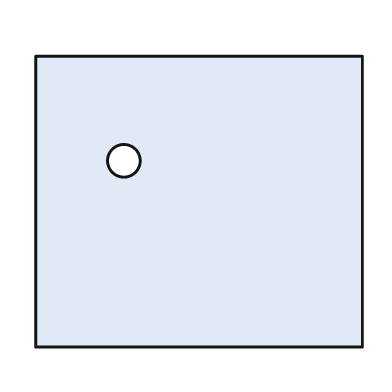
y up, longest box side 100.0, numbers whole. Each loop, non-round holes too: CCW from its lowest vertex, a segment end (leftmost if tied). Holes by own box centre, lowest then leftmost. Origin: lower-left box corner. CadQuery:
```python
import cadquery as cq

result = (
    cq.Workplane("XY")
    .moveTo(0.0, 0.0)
    .lineTo(100.0, 0.0)
    .lineTo(100.0, 89.0)
    .lineTo(0.0, 89.0)
    .close()
    .moveTo(27.0, 57.0)
    .circle(5.0)
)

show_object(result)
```